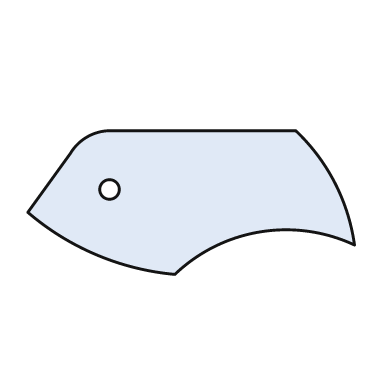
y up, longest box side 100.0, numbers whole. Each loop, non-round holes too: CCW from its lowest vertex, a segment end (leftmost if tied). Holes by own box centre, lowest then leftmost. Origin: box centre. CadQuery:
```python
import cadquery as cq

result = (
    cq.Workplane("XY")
    .moveTo(-5.0, -22.0)
    .threePointArc((21.0, -9.0), (50.0, -13.0))
    .threePointArc((44.0, 6.0), (32.0, 22.0))
    .lineTo(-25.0, 22.0)
    .threePointArc((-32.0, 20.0), (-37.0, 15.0))
    .lineTo(-50.0, -3.0)
    .threePointArc((-29.0, -16.0), (-5.0, -22.0))
    .close()
    .moveTo(-25.0, 4.0)
    .circle(3.0)
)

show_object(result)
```